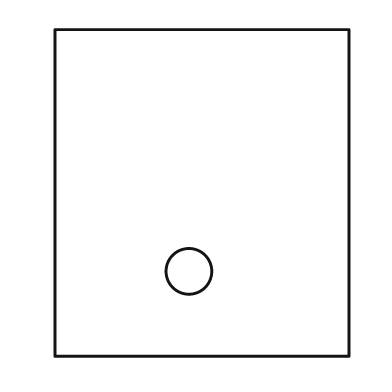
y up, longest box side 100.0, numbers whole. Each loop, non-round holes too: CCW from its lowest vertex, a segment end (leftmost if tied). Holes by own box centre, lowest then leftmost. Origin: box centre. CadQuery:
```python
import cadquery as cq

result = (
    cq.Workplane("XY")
    .moveTo(-45.0, -50.0)
    .lineTo(45.0, -50.0)
    .lineTo(45.0, 50.0)
    .lineTo(-45.0, 50.0)
    .close()
    .moveTo(-4.0, -24.0)
    .circle(7.0)
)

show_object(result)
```